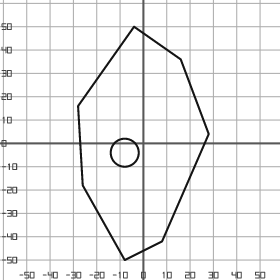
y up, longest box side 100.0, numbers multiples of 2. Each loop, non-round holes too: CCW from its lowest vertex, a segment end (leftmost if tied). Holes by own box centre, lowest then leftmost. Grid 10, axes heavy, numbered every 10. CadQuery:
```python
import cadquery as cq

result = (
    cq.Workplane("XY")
    .moveTo(-8.0, -50.0)
    .lineTo(8.0, -42.0)
    .lineTo(28.0, 4.0)
    .lineTo(16.0, 36.0)
    .lineTo(-4.0, 50.0)
    .lineTo(-28.0, 16.0)
    .lineTo(-26.0, -18.0)
    .close()
    .moveTo(-8.0, -4.0)
    .circle(6.0)
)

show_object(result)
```